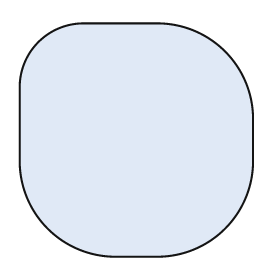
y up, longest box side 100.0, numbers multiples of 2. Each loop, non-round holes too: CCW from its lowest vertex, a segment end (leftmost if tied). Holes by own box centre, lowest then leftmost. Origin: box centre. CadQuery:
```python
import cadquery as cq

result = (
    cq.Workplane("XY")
    .moveTo(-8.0, -50.0)
    .lineTo(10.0, -50.0)
    .threePointArc((38.0, -38.0), (50.0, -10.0))
    .lineTo(50.0, 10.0)
    .threePointArc((38.0, 38.0), (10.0, 50.0))
    .lineTo(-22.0, 50.0)
    .threePointArc((-42.0, 42.0), (-50.0, 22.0))
    .lineTo(-50.0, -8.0)
    .threePointArc((-38.0, -38.0), (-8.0, -50.0))
    .close()
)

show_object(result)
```